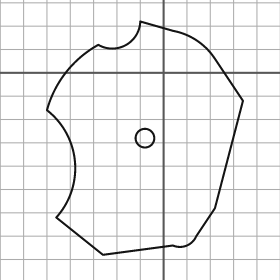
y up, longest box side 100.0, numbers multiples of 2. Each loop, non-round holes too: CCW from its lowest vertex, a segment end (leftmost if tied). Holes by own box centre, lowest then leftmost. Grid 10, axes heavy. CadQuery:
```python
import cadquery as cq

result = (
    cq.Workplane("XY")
    .moveTo(-26.0, -78.0)
    .lineTo(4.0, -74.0)
    .threePointArc((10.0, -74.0), (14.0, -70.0))
    .lineTo(22.0, -58.0)
    .lineTo(34.0, -12.0)
    .lineTo(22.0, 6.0)
    .threePointArc((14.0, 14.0), (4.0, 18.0))
    .lineTo(-10.0, 22.0)
    .threePointArc((-16.0, 12.0), (-28.0, 12.0))
    .threePointArc((-42.0, 0.0), (-50.0, -16.0))
    .threePointArc((-38.0, -38.0), (-46.0, -62.0))
    .close()
    .moveTo(-8.0, -28.0)
    .circle(4.0)
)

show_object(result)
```